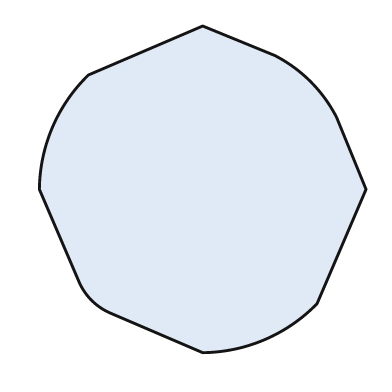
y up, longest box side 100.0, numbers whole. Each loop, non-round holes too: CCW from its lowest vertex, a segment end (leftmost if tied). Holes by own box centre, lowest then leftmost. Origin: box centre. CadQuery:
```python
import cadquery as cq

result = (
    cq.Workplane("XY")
    .moveTo(0.0, -50.0)
    .threePointArc((19.0, -46.0), (35.0, -35.0))
    .lineTo(50.0, 0.0)
    .lineTo(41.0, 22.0)
    .threePointArc((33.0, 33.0), (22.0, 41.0))
    .lineTo(0.0, 50.0)
    .lineTo(-35.0, 35.0)
    .threePointArc((-46.0, 19.0), (-50.0, 0.0))
    .lineTo(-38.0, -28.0)
    .threePointArc((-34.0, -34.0), (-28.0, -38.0))
    .close()
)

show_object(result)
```